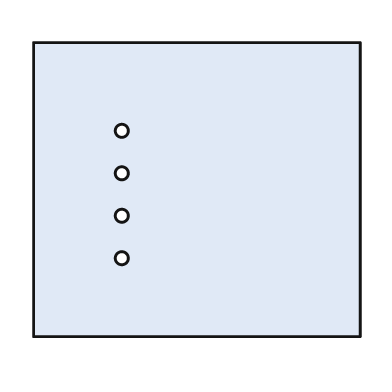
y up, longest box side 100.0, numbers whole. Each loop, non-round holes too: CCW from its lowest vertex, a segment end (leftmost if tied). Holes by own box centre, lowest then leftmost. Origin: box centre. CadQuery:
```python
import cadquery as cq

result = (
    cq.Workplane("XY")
    .moveTo(-50.0, -45.0)
    .lineTo(50.0, -45.0)
    .lineTo(50.0, 45.0)
    .lineTo(-50.0, 45.0)
    .close()
    .moveTo(-23.0, -21.0)
    .circle(2.0)
    .moveTo(-23.0, -8.0)
    .circle(2.0)
    .moveTo(-23.0, 5.0)
    .circle(2.0)
    .moveTo(-23.0, 18.0)
    .circle(2.0)
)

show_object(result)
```